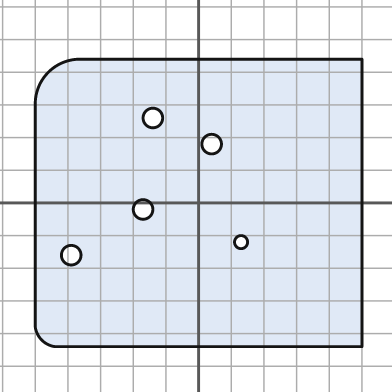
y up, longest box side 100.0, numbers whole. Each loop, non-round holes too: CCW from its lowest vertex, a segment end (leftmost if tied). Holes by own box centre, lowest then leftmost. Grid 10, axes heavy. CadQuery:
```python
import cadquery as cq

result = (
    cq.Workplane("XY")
    .moveTo(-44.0, -44.0)
    .lineTo(50.0, -44.0)
    .lineTo(50.0, 44.0)
    .lineTo(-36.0, 44.0)
    .threePointArc((-46.0, 40.0), (-50.0, 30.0))
    .lineTo(-50.0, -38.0)
    .threePointArc((-48.0, -42.0), (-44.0, -44.0))
    .close()
    .moveTo(-39.0, -16.0)
    .circle(3.0)
    .moveTo(13.0, -12.0)
    .circle(2.0)
    .moveTo(-17.0, -2.0)
    .circle(3.0)
    .moveTo(4.0, 18.0)
    .circle(3.0)
    .moveTo(-14.0, 26.0)
    .circle(3.0)
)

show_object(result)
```